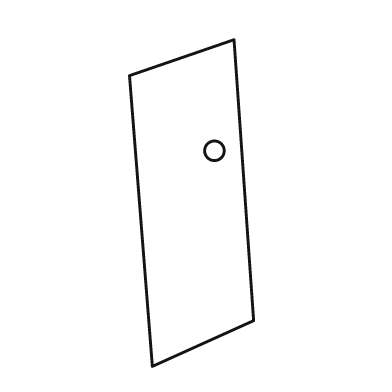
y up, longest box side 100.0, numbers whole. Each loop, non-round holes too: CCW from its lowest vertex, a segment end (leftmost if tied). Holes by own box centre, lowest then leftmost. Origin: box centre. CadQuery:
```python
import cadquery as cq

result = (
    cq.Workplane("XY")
    .moveTo(-12.0, -50.0)
    .lineTo(19.0, -36.0)
    .lineTo(13.0, 50.0)
    .lineTo(-19.0, 39.0)
    .close()
    .moveTo(7.0, 16.0)
    .circle(3.0)
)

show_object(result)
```